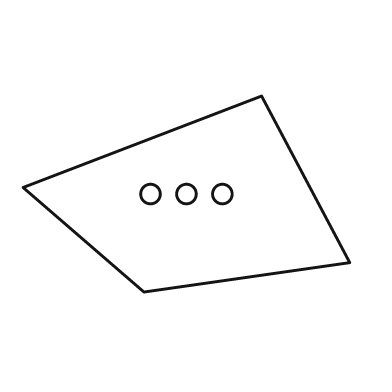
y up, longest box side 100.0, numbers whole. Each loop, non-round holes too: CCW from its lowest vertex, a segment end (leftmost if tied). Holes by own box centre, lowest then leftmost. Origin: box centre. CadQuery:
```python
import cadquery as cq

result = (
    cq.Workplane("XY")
    .moveTo(-13.0, -30.0)
    .lineTo(50.0, -21.0)
    .lineTo(23.0, 30.0)
    .lineTo(-50.0, 2.0)
    .close()
    .moveTo(-11.0, 0.0)
    .circle(3.0)
    .moveTo(0.0, 0.0)
    .circle(3.0)
    .moveTo(11.0, 0.0)
    .circle(3.0)
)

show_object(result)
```